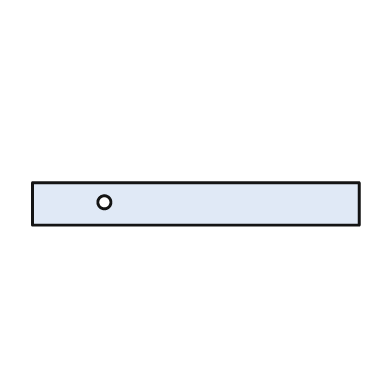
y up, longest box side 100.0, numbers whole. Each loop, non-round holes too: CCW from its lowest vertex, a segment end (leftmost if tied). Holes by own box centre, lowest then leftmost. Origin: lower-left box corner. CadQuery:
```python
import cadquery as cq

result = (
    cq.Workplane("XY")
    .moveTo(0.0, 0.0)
    .lineTo(100.0, 0.0)
    .lineTo(100.0, 13.0)
    .lineTo(0.0, 13.0)
    .close()
    .moveTo(22.0, 7.0)
    .circle(2.0)
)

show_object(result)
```